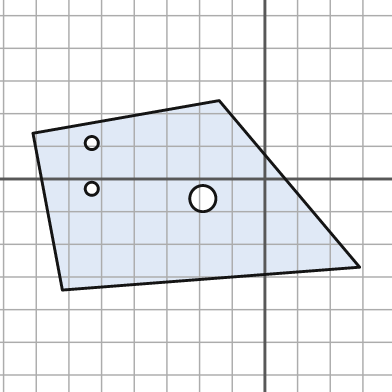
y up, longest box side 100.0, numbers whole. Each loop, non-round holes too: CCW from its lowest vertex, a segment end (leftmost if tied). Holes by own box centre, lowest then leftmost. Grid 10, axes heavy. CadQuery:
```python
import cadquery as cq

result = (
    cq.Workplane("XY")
    .moveTo(-62.0, -34.0)
    .lineTo(29.0, -27.0)
    .lineTo(-14.0, 24.0)
    .lineTo(-71.0, 14.0)
    .close()
    .moveTo(-19.0, -6.0)
    .circle(4.0)
    .moveTo(-53.0, -3.0)
    .circle(2.0)
    .moveTo(-53.0, 11.0)
    .circle(2.0)
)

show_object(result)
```